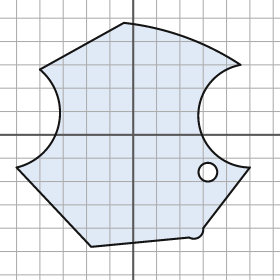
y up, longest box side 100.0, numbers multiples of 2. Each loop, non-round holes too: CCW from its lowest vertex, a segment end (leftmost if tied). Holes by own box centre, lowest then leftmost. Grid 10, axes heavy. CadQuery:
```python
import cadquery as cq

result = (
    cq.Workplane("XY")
    .moveTo(-18.0, -48.0)
    .lineTo(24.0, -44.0)
    .threePointArc((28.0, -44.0), (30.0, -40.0))
    .lineTo(50.0, -14.0)
    .threePointArc((28.0, 6.0), (46.0, 30.0))
    .threePointArc((22.0, 42.0), (-4.0, 48.0))
    .lineTo(-40.0, 28.0)
    .threePointArc((-32.0, 4.0), (-50.0, -14.0))
    .close()
    .moveTo(32.0, -16.0)
    .circle(4.0)
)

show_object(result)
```